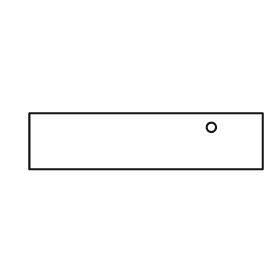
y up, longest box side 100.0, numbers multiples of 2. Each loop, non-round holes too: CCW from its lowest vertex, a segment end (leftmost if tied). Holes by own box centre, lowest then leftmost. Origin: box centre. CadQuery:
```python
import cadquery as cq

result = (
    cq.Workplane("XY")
    .moveTo(-50.0, -12.0)
    .lineTo(50.0, -12.0)
    .lineTo(50.0, 12.0)
    .lineTo(-50.0, 12.0)
    .close()
    .moveTo(28.0, 6.0)
    .circle(2.0)
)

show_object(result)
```